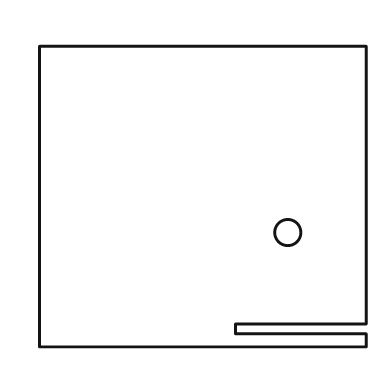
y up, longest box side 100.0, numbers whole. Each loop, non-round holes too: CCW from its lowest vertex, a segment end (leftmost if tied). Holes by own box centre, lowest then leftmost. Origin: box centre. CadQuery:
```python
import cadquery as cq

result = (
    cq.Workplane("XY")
    .moveTo(-50.0, -46.0)
    .lineTo(50.0, -46.0)
    .lineTo(50.0, -42.0)
    .lineTo(10.0, -42.0)
    .lineTo(10.0, -39.0)
    .lineTo(50.0, -39.0)
    .lineTo(50.0, 46.0)
    .lineTo(-50.0, 46.0)
    .close()
    .moveTo(26.0, -11.0)
    .circle(4.0)
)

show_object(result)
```